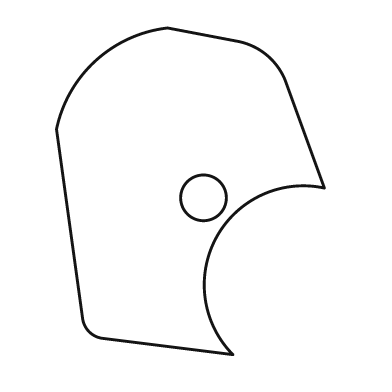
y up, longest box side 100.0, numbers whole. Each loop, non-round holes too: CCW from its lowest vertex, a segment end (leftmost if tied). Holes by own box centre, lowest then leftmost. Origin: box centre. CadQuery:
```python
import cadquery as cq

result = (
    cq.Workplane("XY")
    .moveTo(13.0, -50.0)
    .threePointArc((8.0, -14.0), (41.0, 1.0))
    .lineTo(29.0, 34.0)
    .threePointArc((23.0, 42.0), (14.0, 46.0))
    .lineTo(-7.0, 50.0)
    .threePointArc((-29.0, 40.0), (-41.0, 19.0))
    .lineTo(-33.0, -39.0)
    .threePointArc((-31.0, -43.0), (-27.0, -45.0))
    .close()
    .moveTo(4.0, -2.0)
    .circle(7.0)
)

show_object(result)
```